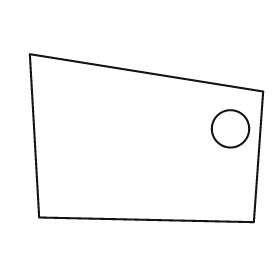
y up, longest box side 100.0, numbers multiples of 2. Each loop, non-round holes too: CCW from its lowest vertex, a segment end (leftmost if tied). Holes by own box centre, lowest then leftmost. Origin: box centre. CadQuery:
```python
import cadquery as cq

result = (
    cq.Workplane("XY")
    .moveTo(46.0, -36.0)
    .lineTo(50.0, 20.0)
    .lineTo(-50.0, 36.0)
    .lineTo(-46.0, -34.0)
    .close()
    .moveTo(36.0, 4.0)
    .circle(8.0)
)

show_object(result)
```